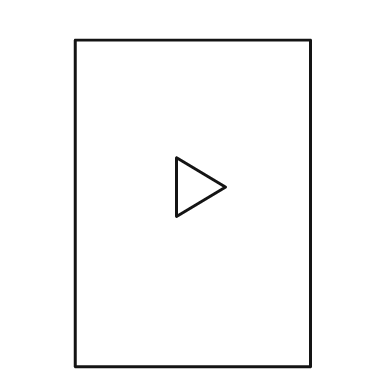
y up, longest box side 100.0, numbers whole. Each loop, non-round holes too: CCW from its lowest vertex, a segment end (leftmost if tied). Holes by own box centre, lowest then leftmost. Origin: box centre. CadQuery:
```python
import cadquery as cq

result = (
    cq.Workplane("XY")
    .moveTo(-36.0, -50.0)
    .lineTo(36.0, -50.0)
    .lineTo(36.0, 50.0)
    .lineTo(-36.0, 50.0)
    .close()
    .moveTo(-5.0, -4.0)
    .lineTo(10.0, 5.0)
    .lineTo(-5.0, 14.0)
    .close()
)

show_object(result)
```